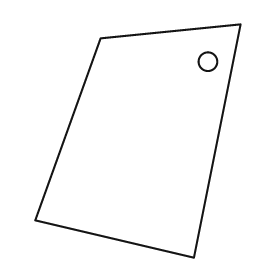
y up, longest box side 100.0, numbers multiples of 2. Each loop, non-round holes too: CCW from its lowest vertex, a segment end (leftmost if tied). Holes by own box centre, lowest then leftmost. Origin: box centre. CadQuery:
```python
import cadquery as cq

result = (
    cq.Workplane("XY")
    .moveTo(24.0, -50.0)
    .lineTo(44.0, 50.0)
    .lineTo(-16.0, 44.0)
    .lineTo(-44.0, -34.0)
    .close()
    .moveTo(30.0, 34.0)
    .circle(4.0)
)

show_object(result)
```